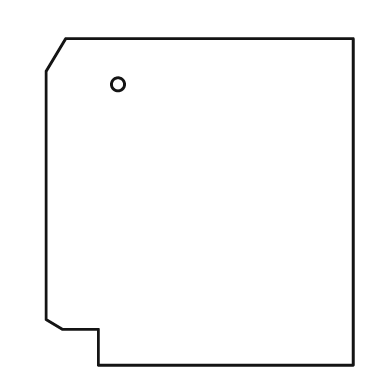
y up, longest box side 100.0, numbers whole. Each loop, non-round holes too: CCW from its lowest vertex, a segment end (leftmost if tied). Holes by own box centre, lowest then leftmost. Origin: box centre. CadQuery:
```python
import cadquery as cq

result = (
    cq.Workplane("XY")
    .moveTo(-31.0, -50.0)
    .lineTo(47.0, -50.0)
    .lineTo(47.0, 50.0)
    .lineTo(-41.0, 50.0)
    .lineTo(-47.0, 40.0)
    .lineTo(-47.0, -36.0)
    .lineTo(-42.0, -39.0)
    .lineTo(-31.0, -39.0)
    .close()
    .moveTo(-25.0, 36.0)
    .circle(2.0)
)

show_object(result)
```